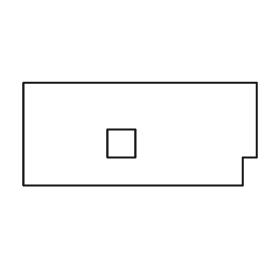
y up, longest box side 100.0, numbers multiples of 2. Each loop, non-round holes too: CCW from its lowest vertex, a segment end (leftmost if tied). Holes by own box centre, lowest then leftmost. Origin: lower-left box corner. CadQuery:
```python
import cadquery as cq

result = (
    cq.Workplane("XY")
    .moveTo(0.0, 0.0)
    .lineTo(94.0, 0.0)
    .lineTo(94.0, 12.0)
    .lineTo(100.0, 12.0)
    .lineTo(100.0, 44.0)
    .lineTo(0.0, 44.0)
    .close()
    .moveTo(36.0, 12.0)
    .lineTo(48.0, 12.0)
    .lineTo(48.0, 24.0)
    .lineTo(36.0, 24.0)
    .close()
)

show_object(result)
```